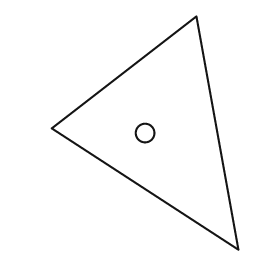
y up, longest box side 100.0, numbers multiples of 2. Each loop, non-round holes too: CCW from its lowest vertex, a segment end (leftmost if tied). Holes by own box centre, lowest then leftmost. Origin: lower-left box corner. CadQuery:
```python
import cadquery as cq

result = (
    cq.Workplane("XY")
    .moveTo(80.0, 0.0)
    .lineTo(62.0, 100.0)
    .lineTo(0.0, 52.0)
    .close()
    .moveTo(40.0, 50.0)
    .circle(4.0)
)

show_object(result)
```